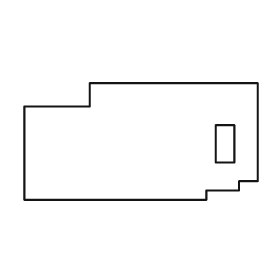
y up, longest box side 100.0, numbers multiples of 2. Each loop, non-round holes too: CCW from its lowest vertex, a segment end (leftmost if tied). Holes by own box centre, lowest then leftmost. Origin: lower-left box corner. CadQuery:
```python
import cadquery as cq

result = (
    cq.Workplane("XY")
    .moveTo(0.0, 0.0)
    .lineTo(78.0, 0.0)
    .lineTo(78.0, 4.0)
    .lineTo(92.0, 4.0)
    .lineTo(92.0, 8.0)
    .lineTo(100.0, 8.0)
    .lineTo(100.0, 50.0)
    .lineTo(28.0, 50.0)
    .lineTo(28.0, 40.0)
    .lineTo(0.0, 40.0)
    .close()
    .moveTo(82.0, 16.0)
    .lineTo(90.0, 16.0)
    .lineTo(90.0, 32.0)
    .lineTo(82.0, 32.0)
    .close()
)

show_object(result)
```